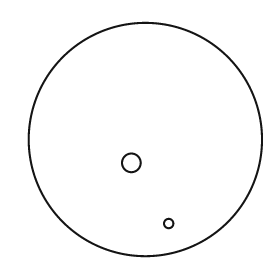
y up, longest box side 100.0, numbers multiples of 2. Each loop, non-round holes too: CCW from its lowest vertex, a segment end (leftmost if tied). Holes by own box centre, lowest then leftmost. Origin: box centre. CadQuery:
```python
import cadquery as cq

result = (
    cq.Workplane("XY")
    .moveTo(0.0, 0.0)
    .circle(50.0)
    .moveTo(10.0, -36.0)
    .circle(2.0)
    .moveTo(-6.0, -10.0)
    .circle(4.0)
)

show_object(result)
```